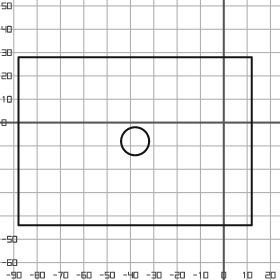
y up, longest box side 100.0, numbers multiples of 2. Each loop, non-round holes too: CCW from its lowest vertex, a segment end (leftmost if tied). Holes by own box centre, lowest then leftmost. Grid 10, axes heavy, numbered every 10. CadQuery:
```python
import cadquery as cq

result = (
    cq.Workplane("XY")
    .moveTo(-88.0, -44.0)
    .lineTo(12.0, -44.0)
    .lineTo(12.0, 28.0)
    .lineTo(-88.0, 28.0)
    .close()
    .moveTo(-38.0, -8.0)
    .circle(6.0)
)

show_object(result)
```